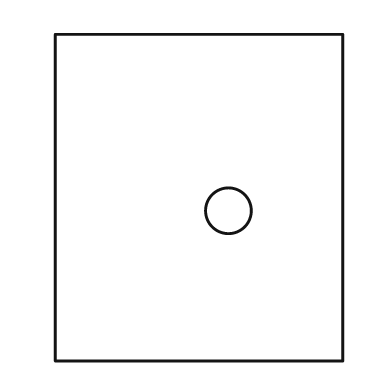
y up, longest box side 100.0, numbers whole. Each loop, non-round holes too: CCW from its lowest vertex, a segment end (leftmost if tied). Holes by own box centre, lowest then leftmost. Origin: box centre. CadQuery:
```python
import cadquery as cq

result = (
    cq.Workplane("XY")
    .moveTo(-44.0, -50.0)
    .lineTo(44.0, -50.0)
    .lineTo(44.0, 50.0)
    .lineTo(-44.0, 50.0)
    .close()
    .moveTo(9.0, -4.0)
    .circle(7.0)
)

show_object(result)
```